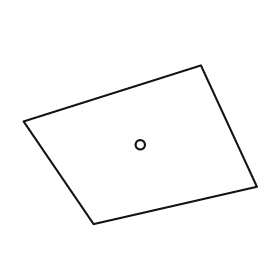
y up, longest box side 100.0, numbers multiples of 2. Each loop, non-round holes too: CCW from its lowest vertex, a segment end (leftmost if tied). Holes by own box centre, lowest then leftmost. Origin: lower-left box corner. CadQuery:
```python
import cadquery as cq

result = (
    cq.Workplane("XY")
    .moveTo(30.0, 0.0)
    .lineTo(100.0, 16.0)
    .lineTo(76.0, 68.0)
    .lineTo(0.0, 44.0)
    .close()
    .moveTo(50.0, 34.0)
    .circle(2.0)
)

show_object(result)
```